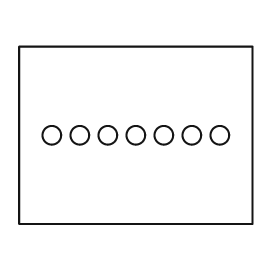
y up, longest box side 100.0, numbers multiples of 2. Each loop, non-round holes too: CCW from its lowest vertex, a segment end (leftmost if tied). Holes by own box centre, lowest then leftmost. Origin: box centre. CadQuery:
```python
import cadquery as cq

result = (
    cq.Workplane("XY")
    .moveTo(-50.0, -38.0)
    .lineTo(50.0, -38.0)
    .lineTo(50.0, 38.0)
    .lineTo(-50.0, 38.0)
    .close()
    .moveTo(-36.0, 0.0)
    .circle(4.0)
    .moveTo(-24.0, 0.0)
    .circle(4.0)
    .moveTo(-12.0, 0.0)
    .circle(4.0)
    .moveTo(0.0, 0.0)
    .circle(4.0)
    .moveTo(12.0, 0.0)
    .circle(4.0)
    .moveTo(24.0, 0.0)
    .circle(4.0)
    .moveTo(36.0, 0.0)
    .circle(4.0)
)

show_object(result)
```